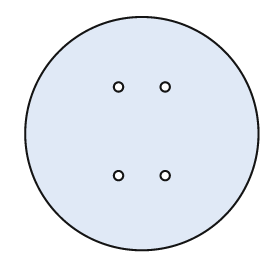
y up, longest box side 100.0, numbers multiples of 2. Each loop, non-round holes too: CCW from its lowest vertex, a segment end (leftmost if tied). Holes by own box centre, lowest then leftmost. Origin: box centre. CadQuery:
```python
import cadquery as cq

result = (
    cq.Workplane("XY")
    .moveTo(0.0, 0.0)
    .circle(50.0)
    .moveTo(-10.0, -18.0)
    .circle(2.0)
    .moveTo(10.0, -18.0)
    .circle(2.0)
    .moveTo(-10.0, 20.0)
    .circle(2.0)
    .moveTo(10.0, 20.0)
    .circle(2.0)
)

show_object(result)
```